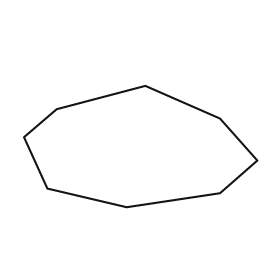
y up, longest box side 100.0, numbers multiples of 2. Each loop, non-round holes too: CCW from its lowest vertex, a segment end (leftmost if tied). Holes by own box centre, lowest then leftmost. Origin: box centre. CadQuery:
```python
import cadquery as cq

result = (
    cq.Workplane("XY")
    .moveTo(-6.0, -26.0)
    .lineTo(34.0, -20.0)
    .lineTo(50.0, -6.0)
    .lineTo(34.0, 12.0)
    .lineTo(2.0, 26.0)
    .lineTo(-36.0, 16.0)
    .lineTo(-50.0, 4.0)
    .lineTo(-40.0, -18.0)
    .close()
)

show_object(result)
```